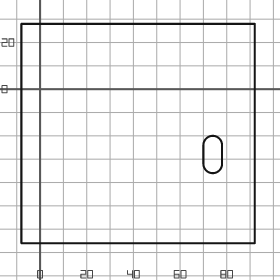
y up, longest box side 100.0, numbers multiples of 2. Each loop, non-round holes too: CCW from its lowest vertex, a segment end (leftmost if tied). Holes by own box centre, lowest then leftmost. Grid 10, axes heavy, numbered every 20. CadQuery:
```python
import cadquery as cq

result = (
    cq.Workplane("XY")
    .moveTo(-8.0, -66.0)
    .lineTo(92.0, -66.0)
    .lineTo(92.0, 28.0)
    .lineTo(-8.0, 28.0)
    .close()
    .moveTo(70.0, -32.0)
    .threePointArc((74.0, -36.0), (78.0, -32.0))
    .lineTo(78.0, -24.0)
    .threePointArc((74.0, -20.0), (70.0, -24.0))
    .close()
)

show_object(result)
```